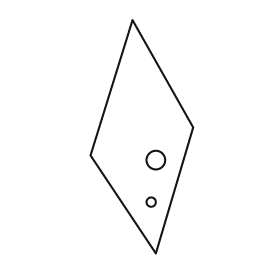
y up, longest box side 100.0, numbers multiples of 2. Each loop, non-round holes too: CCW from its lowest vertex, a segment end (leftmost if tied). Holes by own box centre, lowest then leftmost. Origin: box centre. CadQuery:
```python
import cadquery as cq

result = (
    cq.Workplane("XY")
    .moveTo(6.0, -50.0)
    .lineTo(22.0, 4.0)
    .lineTo(-4.0, 50.0)
    .lineTo(-22.0, -8.0)
    .close()
    .moveTo(4.0, -28.0)
    .circle(2.0)
    .moveTo(6.0, -10.0)
    .circle(4.0)
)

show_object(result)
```